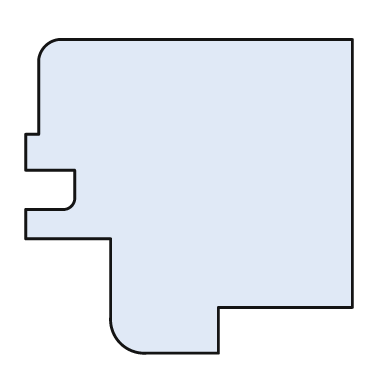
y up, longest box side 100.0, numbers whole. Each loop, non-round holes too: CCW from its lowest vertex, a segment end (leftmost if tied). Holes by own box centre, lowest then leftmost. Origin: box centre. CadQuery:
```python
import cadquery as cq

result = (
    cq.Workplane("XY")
    .moveTo(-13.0, -48.0)
    .lineTo(9.0, -48.0)
    .lineTo(9.0, -34.0)
    .lineTo(50.0, -34.0)
    .lineTo(50.0, 48.0)
    .lineTo(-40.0, 48.0)
    .threePointArc((-44.0, 46.0), (-46.0, 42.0))
    .lineTo(-46.0, 19.0)
    .lineTo(-50.0, 19.0)
    .lineTo(-50.0, 8.0)
    .lineTo(-35.0, 8.0)
    .lineTo(-35.0, 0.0)
    .threePointArc((-36.0, -3.0), (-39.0, -4.0))
    .lineTo(-50.0, -4.0)
    .lineTo(-50.0, -13.0)
    .lineTo(-24.0, -13.0)
    .lineTo(-24.0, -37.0)
    .threePointArc((-21.0, -45.0), (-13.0, -48.0))
    .close()
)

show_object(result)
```